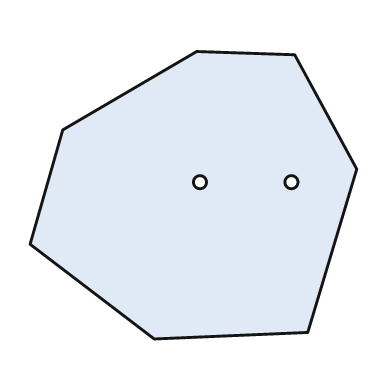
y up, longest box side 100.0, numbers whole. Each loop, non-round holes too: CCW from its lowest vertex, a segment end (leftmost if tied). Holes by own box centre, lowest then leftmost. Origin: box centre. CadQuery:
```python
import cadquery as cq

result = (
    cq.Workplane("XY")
    .moveTo(-12.0, -44.0)
    .lineTo(35.0, -42.0)
    .lineTo(50.0, 8.0)
    .lineTo(31.0, 43.0)
    .lineTo(1.0, 44.0)
    .lineTo(-40.0, 20.0)
    .lineTo(-50.0, -15.0)
    .close()
    .moveTo(2.0, 4.0)
    .circle(2.0)
    .moveTo(30.0, 4.0)
    .circle(2.0)
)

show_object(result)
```